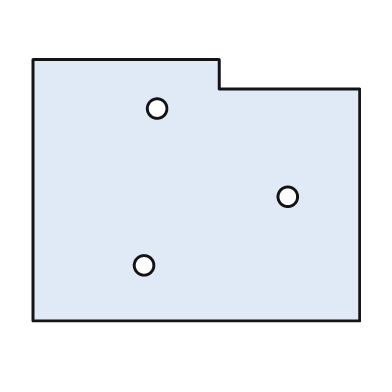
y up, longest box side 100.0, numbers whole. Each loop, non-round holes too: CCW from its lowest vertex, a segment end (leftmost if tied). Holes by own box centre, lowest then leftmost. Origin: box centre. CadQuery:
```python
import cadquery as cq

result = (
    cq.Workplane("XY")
    .moveTo(-50.0, -40.0)
    .lineTo(50.0, -40.0)
    .lineTo(50.0, 31.0)
    .lineTo(7.0, 31.0)
    .lineTo(7.0, 40.0)
    .lineTo(-50.0, 40.0)
    .close()
    .moveTo(-16.0, -23.0)
    .circle(3.0)
    .moveTo(28.0, -2.0)
    .circle(3.0)
    .moveTo(-12.0, 25.0)
    .circle(3.0)
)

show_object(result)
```